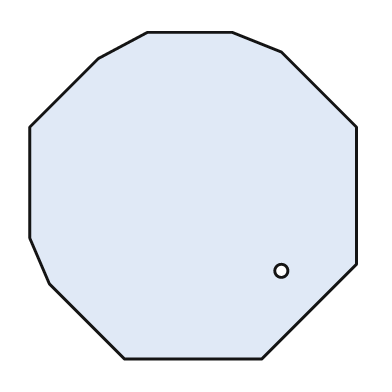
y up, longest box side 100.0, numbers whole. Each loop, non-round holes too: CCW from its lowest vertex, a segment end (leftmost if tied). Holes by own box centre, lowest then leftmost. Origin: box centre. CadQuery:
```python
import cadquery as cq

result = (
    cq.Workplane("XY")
    .moveTo(-21.0, -50.0)
    .lineTo(21.0, -50.0)
    .lineTo(50.0, -21.0)
    .lineTo(50.0, 21.0)
    .lineTo(27.0, 44.0)
    .lineTo(12.0, 50.0)
    .lineTo(-14.0, 50.0)
    .lineTo(-29.0, 42.0)
    .lineTo(-50.0, 21.0)
    .lineTo(-50.0, -13.0)
    .lineTo(-44.0, -27.0)
    .close()
    .moveTo(27.0, -23.0)
    .circle(2.0)
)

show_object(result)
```